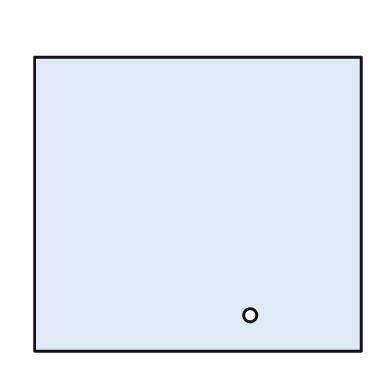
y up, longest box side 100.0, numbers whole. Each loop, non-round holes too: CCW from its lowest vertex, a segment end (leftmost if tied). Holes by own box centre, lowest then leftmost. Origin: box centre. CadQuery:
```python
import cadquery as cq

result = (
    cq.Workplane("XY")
    .moveTo(-50.0, -45.0)
    .lineTo(50.0, -45.0)
    .lineTo(50.0, 45.0)
    .lineTo(-50.0, 45.0)
    .close()
    .moveTo(16.0, -34.0)
    .circle(2.0)
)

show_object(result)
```